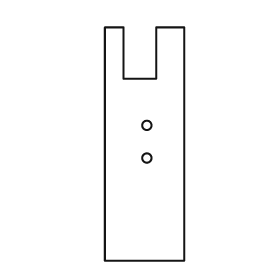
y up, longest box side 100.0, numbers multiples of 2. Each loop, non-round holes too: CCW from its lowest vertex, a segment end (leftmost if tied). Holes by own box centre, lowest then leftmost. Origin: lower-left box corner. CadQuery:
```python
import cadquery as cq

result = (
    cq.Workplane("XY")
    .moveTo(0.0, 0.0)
    .lineTo(34.0, 0.0)
    .lineTo(34.0, 100.0)
    .lineTo(22.0, 100.0)
    .lineTo(22.0, 78.0)
    .lineTo(8.0, 78.0)
    .lineTo(8.0, 100.0)
    .lineTo(0.0, 100.0)
    .close()
    .moveTo(18.0, 44.0)
    .circle(2.0)
    .moveTo(18.0, 58.0)
    .circle(2.0)
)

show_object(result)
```